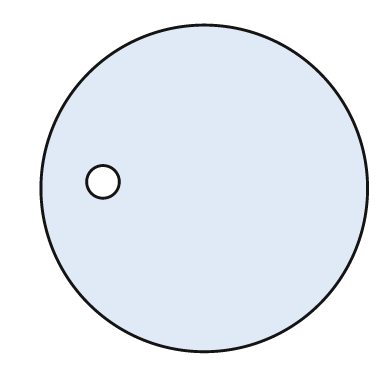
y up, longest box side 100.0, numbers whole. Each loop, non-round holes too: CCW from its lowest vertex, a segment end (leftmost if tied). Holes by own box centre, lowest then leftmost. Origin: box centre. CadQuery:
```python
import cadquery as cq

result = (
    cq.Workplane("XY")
    .moveTo(0.0, 0.0)
    .circle(50.0)
    .moveTo(-31.0, 2.0)
    .circle(5.0)
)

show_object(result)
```